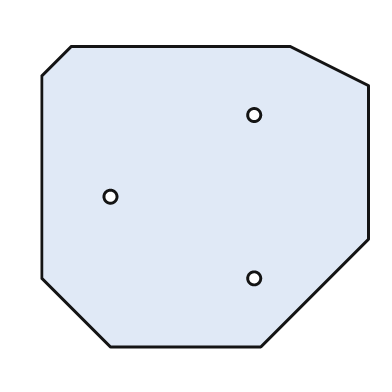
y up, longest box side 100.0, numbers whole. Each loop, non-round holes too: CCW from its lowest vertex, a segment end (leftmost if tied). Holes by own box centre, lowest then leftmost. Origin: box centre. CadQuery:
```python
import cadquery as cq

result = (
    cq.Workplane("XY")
    .moveTo(-29.0, -46.0)
    .lineTo(17.0, -46.0)
    .lineTo(50.0, -13.0)
    .lineTo(50.0, 34.0)
    .lineTo(26.0, 46.0)
    .lineTo(-41.0, 46.0)
    .lineTo(-50.0, 37.0)
    .lineTo(-50.0, -25.0)
    .close()
    .moveTo(15.0, -25.0)
    .circle(2.0)
    .moveTo(-29.0, 0.0)
    .circle(2.0)
    .moveTo(15.0, 25.0)
    .circle(2.0)
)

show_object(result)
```